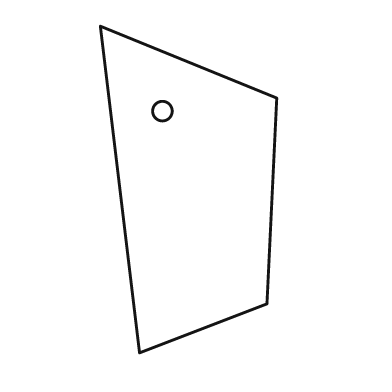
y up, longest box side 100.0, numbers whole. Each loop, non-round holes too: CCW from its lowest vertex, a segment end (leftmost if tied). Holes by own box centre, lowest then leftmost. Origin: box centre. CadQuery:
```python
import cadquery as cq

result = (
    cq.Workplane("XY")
    .moveTo(-15.0, -50.0)
    .lineTo(24.0, -35.0)
    .lineTo(27.0, 28.0)
    .lineTo(-27.0, 50.0)
    .close()
    .moveTo(-8.0, 24.0)
    .circle(3.0)
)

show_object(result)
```